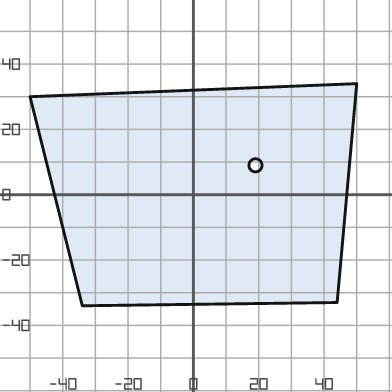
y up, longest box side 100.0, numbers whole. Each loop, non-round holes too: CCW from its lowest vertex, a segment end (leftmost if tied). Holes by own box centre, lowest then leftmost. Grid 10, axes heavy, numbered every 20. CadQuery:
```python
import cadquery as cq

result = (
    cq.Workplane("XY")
    .moveTo(-34.0, -34.0)
    .lineTo(44.0, -33.0)
    .lineTo(50.0, 34.0)
    .lineTo(-50.0, 30.0)
    .close()
    .moveTo(19.0, 9.0)
    .circle(2.0)
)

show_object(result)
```